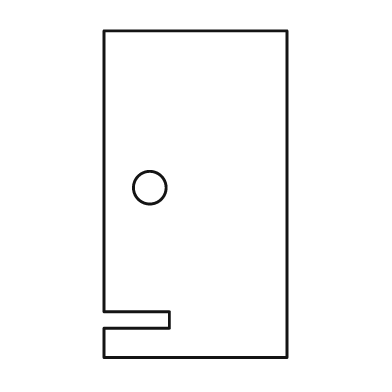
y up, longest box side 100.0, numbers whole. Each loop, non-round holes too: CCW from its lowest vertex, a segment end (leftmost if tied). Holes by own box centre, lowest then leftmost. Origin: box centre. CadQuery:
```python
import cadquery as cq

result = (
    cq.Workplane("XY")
    .moveTo(-28.0, -50.0)
    .lineTo(28.0, -50.0)
    .lineTo(28.0, 50.0)
    .lineTo(-28.0, 50.0)
    .lineTo(-28.0, -36.0)
    .lineTo(-8.0, -36.0)
    .lineTo(-8.0, -41.0)
    .lineTo(-28.0, -41.0)
    .close()
    .moveTo(-14.0, 2.0)
    .circle(5.0)
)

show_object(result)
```